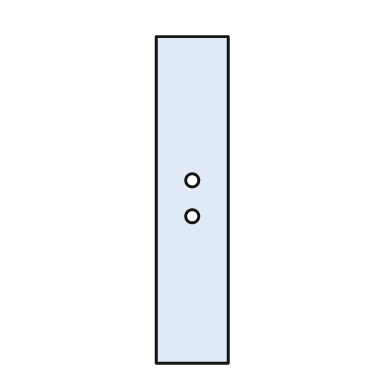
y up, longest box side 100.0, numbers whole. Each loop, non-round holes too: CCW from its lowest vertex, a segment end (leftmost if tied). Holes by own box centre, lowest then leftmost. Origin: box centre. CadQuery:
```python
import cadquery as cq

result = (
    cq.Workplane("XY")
    .moveTo(-11.0, -50.0)
    .lineTo(11.0, -50.0)
    .lineTo(11.0, 50.0)
    .lineTo(-11.0, 50.0)
    .close()
    .moveTo(0.0, -5.0)
    .circle(2.0)
    .moveTo(0.0, 6.0)
    .circle(2.0)
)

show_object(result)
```